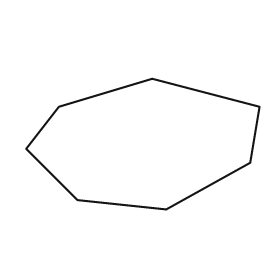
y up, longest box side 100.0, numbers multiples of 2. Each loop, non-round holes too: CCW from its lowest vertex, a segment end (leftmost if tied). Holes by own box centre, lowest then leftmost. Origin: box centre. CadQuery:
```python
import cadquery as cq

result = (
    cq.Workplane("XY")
    .moveTo(10.0, -28.0)
    .lineTo(46.0, -8.0)
    .lineTo(50.0, 16.0)
    .lineTo(4.0, 28.0)
    .lineTo(-36.0, 16.0)
    .lineTo(-50.0, -2.0)
    .lineTo(-28.0, -24.0)
    .close()
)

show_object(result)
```